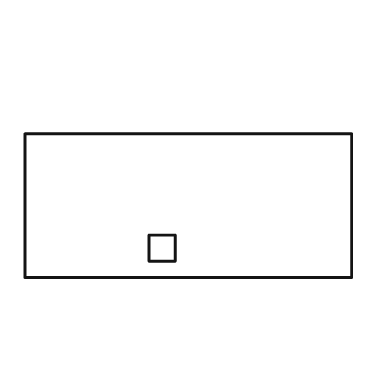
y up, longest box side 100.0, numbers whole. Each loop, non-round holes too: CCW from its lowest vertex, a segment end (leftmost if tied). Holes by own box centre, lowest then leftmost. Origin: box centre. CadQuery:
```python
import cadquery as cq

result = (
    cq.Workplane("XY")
    .moveTo(-50.0, -22.0)
    .lineTo(50.0, -22.0)
    .lineTo(50.0, 22.0)
    .lineTo(-50.0, 22.0)
    .close()
    .moveTo(-12.0, -17.0)
    .lineTo(-4.0, -17.0)
    .lineTo(-4.0, -9.0)
    .lineTo(-12.0, -9.0)
    .close()
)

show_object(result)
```